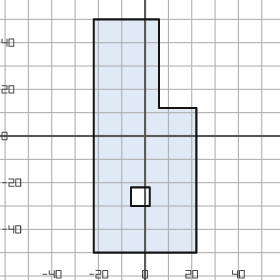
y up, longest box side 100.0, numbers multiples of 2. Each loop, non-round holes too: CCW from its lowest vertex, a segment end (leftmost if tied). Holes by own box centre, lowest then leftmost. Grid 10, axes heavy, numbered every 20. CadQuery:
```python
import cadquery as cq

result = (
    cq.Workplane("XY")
    .moveTo(-22.0, -50.0)
    .lineTo(22.0, -50.0)
    .lineTo(22.0, 12.0)
    .lineTo(6.0, 12.0)
    .lineTo(6.0, 50.0)
    .lineTo(-22.0, 50.0)
    .close()
    .moveTo(-6.0, -30.0)
    .lineTo(2.0, -30.0)
    .lineTo(2.0, -22.0)
    .lineTo(-6.0, -22.0)
    .close()
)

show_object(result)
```